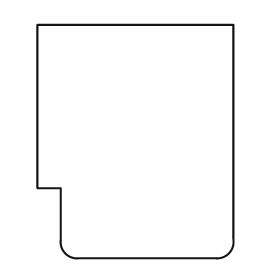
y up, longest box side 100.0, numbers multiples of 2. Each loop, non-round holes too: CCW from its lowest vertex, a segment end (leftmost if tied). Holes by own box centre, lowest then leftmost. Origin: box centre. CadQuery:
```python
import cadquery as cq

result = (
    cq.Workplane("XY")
    .moveTo(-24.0, -50.0)
    .lineTo(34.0, -50.0)
    .threePointArc((40.0, -48.0), (42.0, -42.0))
    .lineTo(42.0, 50.0)
    .lineTo(-42.0, 50.0)
    .lineTo(-42.0, -20.0)
    .lineTo(-32.0, -20.0)
    .lineTo(-32.0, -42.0)
    .threePointArc((-30.0, -48.0), (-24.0, -50.0))
    .close()
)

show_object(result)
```